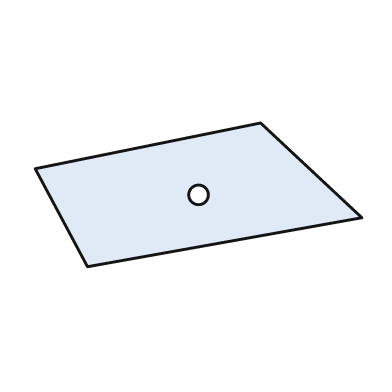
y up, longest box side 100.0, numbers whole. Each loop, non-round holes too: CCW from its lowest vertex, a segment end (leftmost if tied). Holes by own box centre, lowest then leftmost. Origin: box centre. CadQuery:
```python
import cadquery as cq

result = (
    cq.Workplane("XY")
    .moveTo(-34.0, -22.0)
    .lineTo(50.0, -7.0)
    .lineTo(19.0, 22.0)
    .lineTo(-50.0, 8.0)
    .close()
    .moveTo(0.0, 0.0)
    .circle(3.0)
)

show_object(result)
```